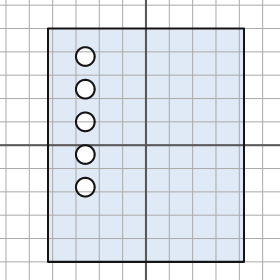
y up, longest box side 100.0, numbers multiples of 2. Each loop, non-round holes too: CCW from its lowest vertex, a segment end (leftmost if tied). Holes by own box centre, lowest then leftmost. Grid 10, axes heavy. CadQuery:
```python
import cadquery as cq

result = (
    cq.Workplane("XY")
    .moveTo(-42.0, -50.0)
    .lineTo(42.0, -50.0)
    .lineTo(42.0, 50.0)
    .lineTo(-42.0, 50.0)
    .close()
    .moveTo(-26.0, -18.0)
    .circle(4.0)
    .moveTo(-26.0, -4.0)
    .circle(4.0)
    .moveTo(-26.0, 10.0)
    .circle(4.0)
    .moveTo(-26.0, 24.0)
    .circle(4.0)
    .moveTo(-26.0, 38.0)
    .circle(4.0)
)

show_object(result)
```